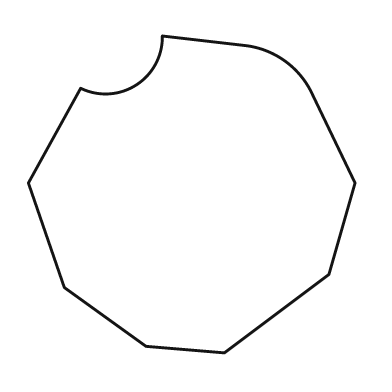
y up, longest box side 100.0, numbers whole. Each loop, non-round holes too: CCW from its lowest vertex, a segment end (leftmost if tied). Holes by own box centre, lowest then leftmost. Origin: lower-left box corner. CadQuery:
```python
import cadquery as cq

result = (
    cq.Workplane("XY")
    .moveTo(60.0, 0.0)
    .lineTo(92.0, 24.0)
    .lineTo(100.0, 52.0)
    .lineTo(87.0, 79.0)
    .threePointArc((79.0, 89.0), (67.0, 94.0))
    .lineTo(41.0, 97.0)
    .threePointArc((33.0, 82.0), (16.0, 81.0))
    .lineTo(0.0, 52.0)
    .lineTo(11.0, 20.0)
    .lineTo(36.0, 2.0)
    .close()
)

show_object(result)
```